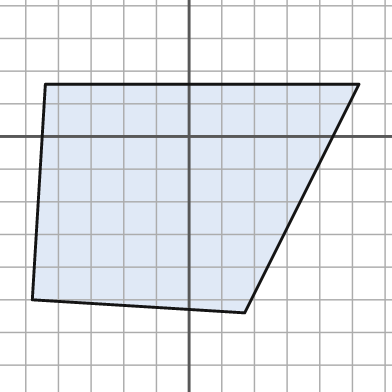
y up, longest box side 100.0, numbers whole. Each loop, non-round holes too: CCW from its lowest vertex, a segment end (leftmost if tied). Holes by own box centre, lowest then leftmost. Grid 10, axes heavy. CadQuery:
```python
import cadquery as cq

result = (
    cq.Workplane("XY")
    .moveTo(17.0, -54.0)
    .lineTo(52.0, 16.0)
    .lineTo(-44.0, 16.0)
    .lineTo(-48.0, -50.0)
    .close()
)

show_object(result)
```